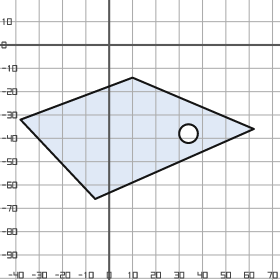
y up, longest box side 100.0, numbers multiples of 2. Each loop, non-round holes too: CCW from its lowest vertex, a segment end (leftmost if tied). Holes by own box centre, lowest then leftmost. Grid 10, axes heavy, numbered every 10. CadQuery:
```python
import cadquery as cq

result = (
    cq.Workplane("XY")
    .moveTo(-6.0, -66.0)
    .lineTo(62.0, -36.0)
    .lineTo(10.0, -14.0)
    .lineTo(-38.0, -32.0)
    .close()
    .moveTo(34.0, -38.0)
    .circle(4.0)
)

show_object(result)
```